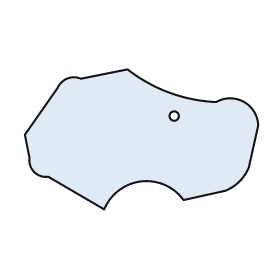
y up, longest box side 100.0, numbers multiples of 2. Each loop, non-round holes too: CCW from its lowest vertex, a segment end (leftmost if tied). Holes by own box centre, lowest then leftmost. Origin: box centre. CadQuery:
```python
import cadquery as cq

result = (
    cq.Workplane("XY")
    .moveTo(-16.0, -30.0)
    .threePointArc((0.0, -18.0), (18.0, -26.0))
    .lineTo(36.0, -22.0)
    .threePointArc((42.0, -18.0), (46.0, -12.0))
    .lineTo(50.0, 6.0)
    .threePointArc((44.0, 16.0), (32.0, 16.0))
    .threePointArc((12.0, 20.0), (-6.0, 30.0))
    .lineTo(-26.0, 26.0)
    .threePointArc((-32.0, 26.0), (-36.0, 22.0))
    .lineTo(-50.0, 2.0)
    .lineTo(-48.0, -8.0)
    .threePointArc((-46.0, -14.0), (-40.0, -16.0))
    .close()
    .moveTo(14.0, 10.0)
    .circle(2.0)
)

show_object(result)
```